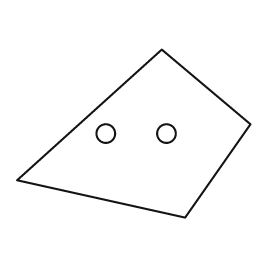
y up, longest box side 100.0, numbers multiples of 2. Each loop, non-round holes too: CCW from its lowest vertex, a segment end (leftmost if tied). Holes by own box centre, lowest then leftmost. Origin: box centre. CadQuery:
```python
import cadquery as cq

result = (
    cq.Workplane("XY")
    .moveTo(22.0, -36.0)
    .lineTo(50.0, 4.0)
    .lineTo(12.0, 36.0)
    .lineTo(-50.0, -20.0)
    .close()
    .moveTo(-12.0, 0.0)
    .circle(4.0)
    .moveTo(14.0, 0.0)
    .circle(4.0)
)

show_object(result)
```